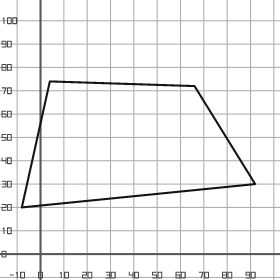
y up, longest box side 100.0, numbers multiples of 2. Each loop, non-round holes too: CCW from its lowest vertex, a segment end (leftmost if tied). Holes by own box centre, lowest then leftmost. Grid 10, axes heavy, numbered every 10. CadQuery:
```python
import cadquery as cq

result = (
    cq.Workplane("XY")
    .moveTo(-8.0, 20.0)
    .lineTo(92.0, 30.0)
    .lineTo(66.0, 72.0)
    .lineTo(4.0, 74.0)
    .close()
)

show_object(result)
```